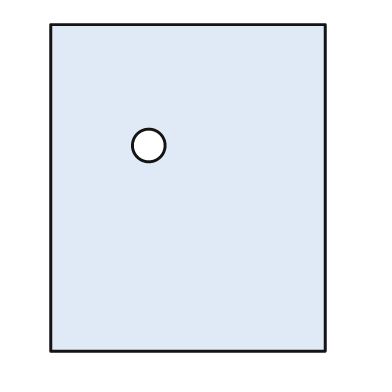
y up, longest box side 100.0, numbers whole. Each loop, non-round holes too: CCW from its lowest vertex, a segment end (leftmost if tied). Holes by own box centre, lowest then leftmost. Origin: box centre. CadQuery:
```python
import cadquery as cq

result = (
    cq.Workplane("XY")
    .moveTo(-42.0, -50.0)
    .lineTo(42.0, -50.0)
    .lineTo(42.0, 50.0)
    .lineTo(-42.0, 50.0)
    .close()
    .moveTo(-12.0, 13.0)
    .circle(5.0)
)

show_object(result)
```